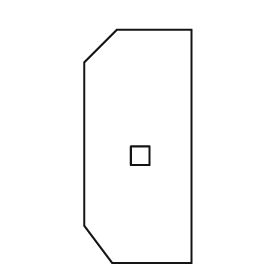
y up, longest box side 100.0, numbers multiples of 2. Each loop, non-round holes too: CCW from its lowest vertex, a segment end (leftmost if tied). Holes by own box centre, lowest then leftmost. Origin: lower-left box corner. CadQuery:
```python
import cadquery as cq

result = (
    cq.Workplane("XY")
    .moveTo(12.0, 0.0)
    .lineTo(46.0, 0.0)
    .lineTo(46.0, 100.0)
    .lineTo(14.0, 100.0)
    .lineTo(0.0, 86.0)
    .lineTo(0.0, 16.0)
    .close()
    .moveTo(20.0, 42.0)
    .lineTo(28.0, 42.0)
    .lineTo(28.0, 50.0)
    .lineTo(20.0, 50.0)
    .close()
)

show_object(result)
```